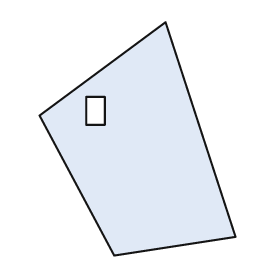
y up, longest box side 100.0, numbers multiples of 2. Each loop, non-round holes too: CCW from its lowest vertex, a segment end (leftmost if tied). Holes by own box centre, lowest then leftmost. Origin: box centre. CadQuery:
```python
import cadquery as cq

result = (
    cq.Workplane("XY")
    .moveTo(-10.0, -50.0)
    .lineTo(42.0, -42.0)
    .lineTo(12.0, 50.0)
    .lineTo(-42.0, 10.0)
    .close()
    .moveTo(-22.0, 6.0)
    .lineTo(-14.0, 6.0)
    .lineTo(-14.0, 18.0)
    .lineTo(-22.0, 18.0)
    .close()
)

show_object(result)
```